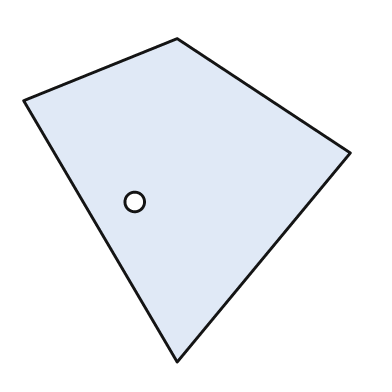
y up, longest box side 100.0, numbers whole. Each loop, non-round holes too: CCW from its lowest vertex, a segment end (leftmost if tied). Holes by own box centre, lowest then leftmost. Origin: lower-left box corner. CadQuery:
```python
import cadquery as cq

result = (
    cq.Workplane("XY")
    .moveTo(47.0, 0.0)
    .lineTo(100.0, 64.0)
    .lineTo(47.0, 99.0)
    .lineTo(0.0, 80.0)
    .close()
    .moveTo(34.0, 49.0)
    .circle(3.0)
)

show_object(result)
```